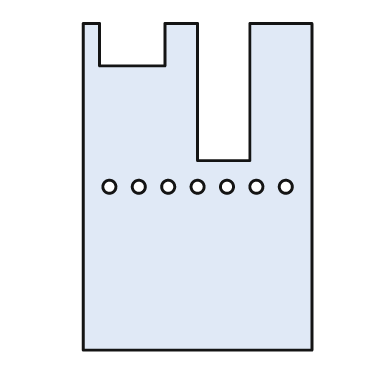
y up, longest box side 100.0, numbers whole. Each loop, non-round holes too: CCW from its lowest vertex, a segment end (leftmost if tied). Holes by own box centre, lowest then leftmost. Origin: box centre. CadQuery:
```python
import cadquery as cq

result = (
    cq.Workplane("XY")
    .moveTo(-35.0, -50.0)
    .lineTo(35.0, -50.0)
    .lineTo(35.0, 50.0)
    .lineTo(16.0, 50.0)
    .lineTo(16.0, 8.0)
    .lineTo(0.0, 8.0)
    .lineTo(0.0, 50.0)
    .lineTo(-10.0, 50.0)
    .lineTo(-10.0, 37.0)
    .lineTo(-30.0, 37.0)
    .lineTo(-30.0, 50.0)
    .lineTo(-35.0, 50.0)
    .close()
    .moveTo(-27.0, 0.0)
    .circle(2.0)
    .moveTo(-18.0, 0.0)
    .circle(2.0)
    .moveTo(-9.0, 0.0)
    .circle(2.0)
    .moveTo(0.0, 0.0)
    .circle(2.0)
    .moveTo(9.0, 0.0)
    .circle(2.0)
    .moveTo(18.0, 0.0)
    .circle(2.0)
    .moveTo(27.0, 0.0)
    .circle(2.0)
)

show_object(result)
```